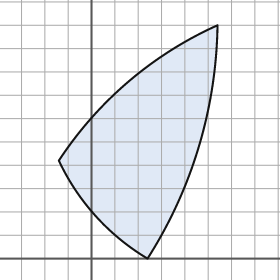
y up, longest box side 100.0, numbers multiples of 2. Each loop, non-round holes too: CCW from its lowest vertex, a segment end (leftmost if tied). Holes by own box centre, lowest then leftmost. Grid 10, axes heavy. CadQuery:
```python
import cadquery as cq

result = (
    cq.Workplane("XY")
    .moveTo(24.0, 0.0)
    .threePointArc((46.0, 48.0), (54.0, 100.0))
    .threePointArc((16.0, 76.0), (-14.0, 42.0))
    .threePointArc((2.0, 18.0), (24.0, 0.0))
    .close()
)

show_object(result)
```